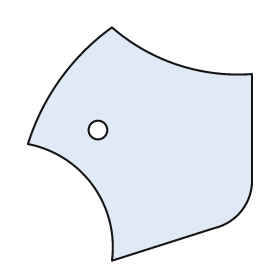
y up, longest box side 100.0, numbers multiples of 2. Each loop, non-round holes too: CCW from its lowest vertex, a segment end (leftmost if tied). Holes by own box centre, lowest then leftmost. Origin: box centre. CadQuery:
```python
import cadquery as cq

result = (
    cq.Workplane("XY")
    .moveTo(-12.0, -50.0)
    .lineTo(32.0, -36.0)
    .threePointArc((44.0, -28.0), (48.0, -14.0))
    .lineTo(48.0, 30.0)
    .threePointArc((16.0, 34.0), (-12.0, 50.0))
    .threePointArc((-34.0, 28.0), (-48.0, 0.0))
    .threePointArc((-20.0, -18.0), (-12.0, -50.0))
    .close()
    .moveTo(-18.0, 6.0)
    .circle(4.0)
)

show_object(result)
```